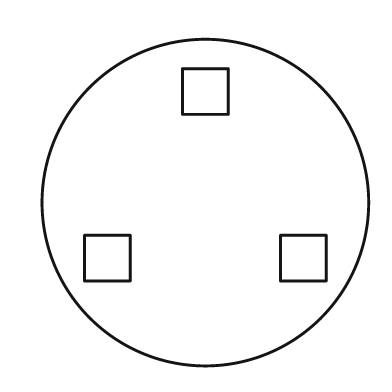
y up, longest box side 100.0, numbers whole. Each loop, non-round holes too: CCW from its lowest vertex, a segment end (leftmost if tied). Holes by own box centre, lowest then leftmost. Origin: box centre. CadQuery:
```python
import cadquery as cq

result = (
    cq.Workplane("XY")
    .moveTo(0.0, 0.0)
    .circle(50.0)
    .moveTo(-37.0, -24.0)
    .lineTo(-23.0, -24.0)
    .lineTo(-23.0, -10.0)
    .lineTo(-37.0, -10.0)
    .close()
    .moveTo(23.0, -24.0)
    .lineTo(37.0, -24.0)
    .lineTo(37.0, -10.0)
    .lineTo(23.0, -10.0)
    .close()
    .moveTo(-7.0, 27.0)
    .lineTo(7.0, 27.0)
    .lineTo(7.0, 41.0)
    .lineTo(-7.0, 41.0)
    .close()
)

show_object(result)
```